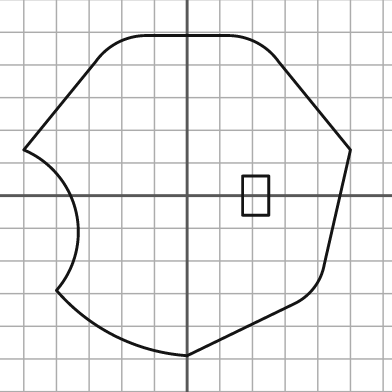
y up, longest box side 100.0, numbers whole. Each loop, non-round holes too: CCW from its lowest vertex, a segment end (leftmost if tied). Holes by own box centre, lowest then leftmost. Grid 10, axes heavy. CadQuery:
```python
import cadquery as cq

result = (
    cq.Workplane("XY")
    .moveTo(0.0, -49.0)
    .lineTo(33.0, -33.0)
    .threePointArc((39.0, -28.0), (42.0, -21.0))
    .lineTo(50.0, 14.0)
    .lineTo(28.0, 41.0)
    .threePointArc((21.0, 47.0), (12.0, 49.0))
    .lineTo(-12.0, 49.0)
    .threePointArc((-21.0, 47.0), (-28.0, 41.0))
    .lineTo(-50.0, 14.0)
    .threePointArc((-34.0, -5.0), (-40.0, -29.0))
    .threePointArc((-22.0, -43.0), (0.0, -49.0))
    .close()
    .moveTo(17.0, -6.0)
    .lineTo(25.0, -6.0)
    .lineTo(25.0, 6.0)
    .lineTo(17.0, 6.0)
    .close()
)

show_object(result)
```